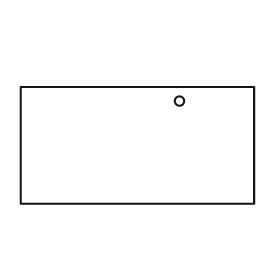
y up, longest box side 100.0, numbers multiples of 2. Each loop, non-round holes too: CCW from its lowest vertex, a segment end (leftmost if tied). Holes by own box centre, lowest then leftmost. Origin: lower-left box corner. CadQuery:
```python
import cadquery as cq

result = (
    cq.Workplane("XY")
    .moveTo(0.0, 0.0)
    .lineTo(100.0, 0.0)
    .lineTo(100.0, 50.0)
    .lineTo(0.0, 50.0)
    .close()
    .moveTo(68.0, 44.0)
    .circle(2.0)
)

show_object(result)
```